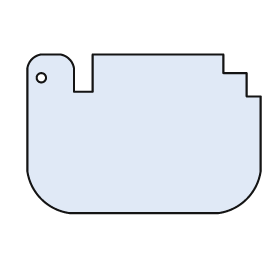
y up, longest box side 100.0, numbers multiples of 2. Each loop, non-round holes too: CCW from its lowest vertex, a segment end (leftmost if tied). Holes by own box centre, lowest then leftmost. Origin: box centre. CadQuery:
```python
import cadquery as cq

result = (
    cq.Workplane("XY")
    .moveTo(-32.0, -34.0)
    .lineTo(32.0, -34.0)
    .threePointArc((44.0, -28.0), (50.0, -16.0))
    .lineTo(50.0, 16.0)
    .lineTo(44.0, 16.0)
    .lineTo(44.0, 26.0)
    .lineTo(34.0, 26.0)
    .lineTo(34.0, 34.0)
    .lineTo(-22.0, 34.0)
    .lineTo(-22.0, 18.0)
    .lineTo(-30.0, 18.0)
    .lineTo(-30.0, 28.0)
    .threePointArc((-32.0, 32.0), (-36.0, 34.0))
    .lineTo(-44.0, 34.0)
    .threePointArc((-48.0, 32.0), (-50.0, 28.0))
    .lineTo(-50.0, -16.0)
    .threePointArc((-44.0, -28.0), (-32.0, -34.0))
    .close()
    .moveTo(-44.0, 24.0)
    .circle(2.0)
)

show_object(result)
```